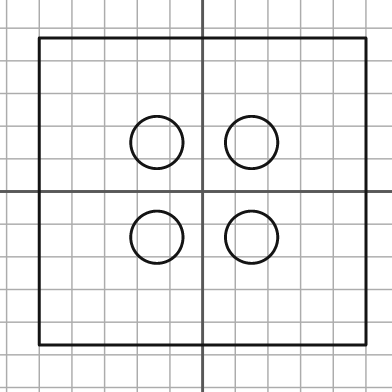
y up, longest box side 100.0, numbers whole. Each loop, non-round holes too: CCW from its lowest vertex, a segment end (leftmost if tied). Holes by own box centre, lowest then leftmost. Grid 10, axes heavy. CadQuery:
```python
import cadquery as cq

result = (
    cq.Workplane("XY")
    .moveTo(-50.0, -47.0)
    .lineTo(50.0, -47.0)
    .lineTo(50.0, 47.0)
    .lineTo(-50.0, 47.0)
    .close()
    .moveTo(-14.0, -14.0)
    .circle(8.0)
    .moveTo(15.0, -14.0)
    .circle(8.0)
    .moveTo(-14.0, 15.0)
    .circle(8.0)
    .moveTo(15.0, 15.0)
    .circle(8.0)
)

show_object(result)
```